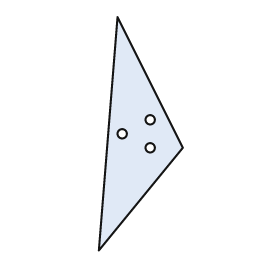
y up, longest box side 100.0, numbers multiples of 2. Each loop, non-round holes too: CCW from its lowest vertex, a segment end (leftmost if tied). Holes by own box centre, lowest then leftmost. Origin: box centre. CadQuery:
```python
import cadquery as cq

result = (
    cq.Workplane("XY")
    .moveTo(-18.0, -50.0)
    .lineTo(18.0, -6.0)
    .lineTo(-10.0, 50.0)
    .close()
    .moveTo(4.0, -6.0)
    .circle(2.0)
    .moveTo(-8.0, 0.0)
    .circle(2.0)
    .moveTo(4.0, 6.0)
    .circle(2.0)
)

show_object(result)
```